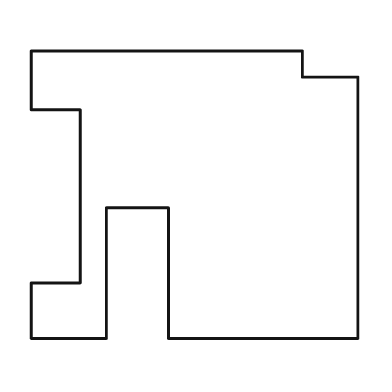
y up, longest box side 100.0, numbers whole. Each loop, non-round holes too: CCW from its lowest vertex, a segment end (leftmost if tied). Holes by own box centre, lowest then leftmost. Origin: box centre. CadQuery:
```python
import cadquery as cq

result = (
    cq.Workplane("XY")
    .moveTo(-50.0, -44.0)
    .lineTo(-27.0, -44.0)
    .lineTo(-27.0, -4.0)
    .lineTo(-8.0, -4.0)
    .lineTo(-8.0, -44.0)
    .lineTo(50.0, -44.0)
    .lineTo(50.0, 36.0)
    .lineTo(33.0, 36.0)
    .lineTo(33.0, 44.0)
    .lineTo(-50.0, 44.0)
    .lineTo(-50.0, 26.0)
    .lineTo(-35.0, 26.0)
    .lineTo(-35.0, -27.0)
    .lineTo(-50.0, -27.0)
    .close()
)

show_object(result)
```